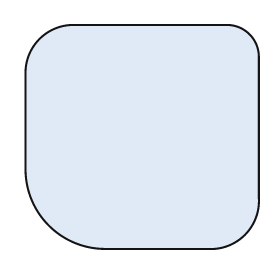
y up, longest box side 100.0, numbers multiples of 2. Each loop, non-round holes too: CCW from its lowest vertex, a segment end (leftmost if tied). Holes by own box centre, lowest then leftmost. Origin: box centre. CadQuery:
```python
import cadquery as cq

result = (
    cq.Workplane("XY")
    .moveTo(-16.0, -48.0)
    .lineTo(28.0, -48.0)
    .threePointArc((44.0, -42.0), (50.0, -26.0))
    .lineTo(50.0, 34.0)
    .threePointArc((46.0, 44.0), (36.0, 48.0))
    .lineTo(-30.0, 48.0)
    .threePointArc((-44.0, 42.0), (-50.0, 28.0))
    .lineTo(-50.0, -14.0)
    .threePointArc((-40.0, -38.0), (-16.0, -48.0))
    .close()
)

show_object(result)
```